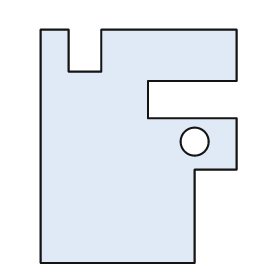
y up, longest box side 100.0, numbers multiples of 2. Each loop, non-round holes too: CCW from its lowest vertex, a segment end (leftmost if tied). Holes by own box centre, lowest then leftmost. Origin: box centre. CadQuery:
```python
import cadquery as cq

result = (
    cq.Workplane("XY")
    .moveTo(-42.0, -50.0)
    .lineTo(24.0, -50.0)
    .lineTo(24.0, -10.0)
    .lineTo(42.0, -10.0)
    .lineTo(42.0, 12.0)
    .lineTo(4.0, 12.0)
    .lineTo(4.0, 28.0)
    .lineTo(42.0, 28.0)
    .lineTo(42.0, 50.0)
    .lineTo(-16.0, 50.0)
    .lineTo(-16.0, 32.0)
    .lineTo(-30.0, 32.0)
    .lineTo(-30.0, 50.0)
    .lineTo(-42.0, 50.0)
    .close()
    .moveTo(24.0, 2.0)
    .circle(6.0)
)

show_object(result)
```